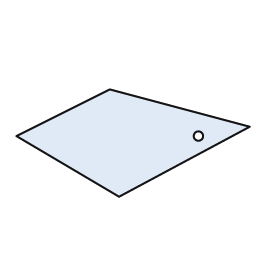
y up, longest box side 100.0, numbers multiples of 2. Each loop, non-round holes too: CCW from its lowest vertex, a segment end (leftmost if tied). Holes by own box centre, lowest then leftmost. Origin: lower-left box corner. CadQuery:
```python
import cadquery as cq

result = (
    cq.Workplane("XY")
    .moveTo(44.0, 0.0)
    .lineTo(100.0, 30.0)
    .lineTo(40.0, 46.0)
    .lineTo(0.0, 26.0)
    .close()
    .moveTo(78.0, 26.0)
    .circle(2.0)
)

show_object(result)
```